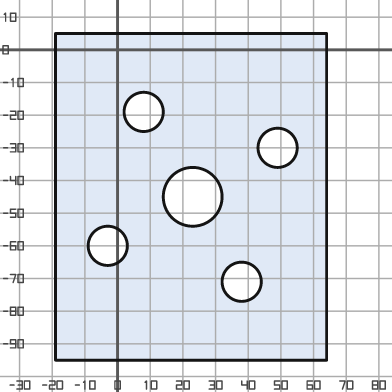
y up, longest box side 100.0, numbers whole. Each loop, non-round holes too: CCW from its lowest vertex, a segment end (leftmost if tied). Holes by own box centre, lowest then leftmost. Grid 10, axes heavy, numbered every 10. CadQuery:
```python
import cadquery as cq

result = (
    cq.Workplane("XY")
    .moveTo(-19.0, -95.0)
    .lineTo(64.0, -95.0)
    .lineTo(64.0, 5.0)
    .lineTo(-19.0, 5.0)
    .close()
    .moveTo(38.0, -71.0)
    .circle(6.0)
    .moveTo(-3.0, -60.0)
    .circle(6.0)
    .moveTo(23.0, -45.0)
    .circle(9.0)
    .moveTo(49.0, -30.0)
    .circle(6.0)
    .moveTo(8.0, -19.0)
    .circle(6.0)
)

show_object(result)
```